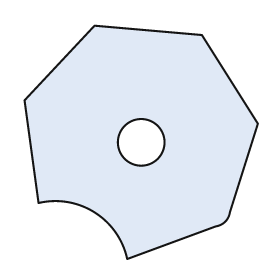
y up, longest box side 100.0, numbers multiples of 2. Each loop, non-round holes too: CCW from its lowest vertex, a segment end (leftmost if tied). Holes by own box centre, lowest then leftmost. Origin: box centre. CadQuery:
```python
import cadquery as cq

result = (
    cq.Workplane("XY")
    .moveTo(-6.0, -50.0)
    .lineTo(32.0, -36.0)
    .threePointArc((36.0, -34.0), (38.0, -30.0))
    .lineTo(50.0, 8.0)
    .lineTo(26.0, 46.0)
    .lineTo(-20.0, 50.0)
    .lineTo(-50.0, 18.0)
    .lineTo(-44.0, -26.0)
    .threePointArc((-20.0, -30.0), (-6.0, -50.0))
    .close()
    .moveTo(0.0, 0.0)
    .circle(10.0)
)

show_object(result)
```